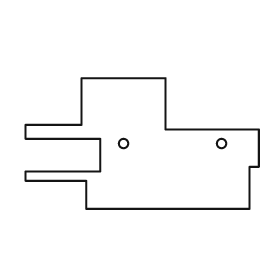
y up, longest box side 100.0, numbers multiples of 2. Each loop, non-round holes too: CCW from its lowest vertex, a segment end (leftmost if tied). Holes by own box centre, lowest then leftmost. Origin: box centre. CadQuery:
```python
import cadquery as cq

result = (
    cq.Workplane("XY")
    .moveTo(-24.0, -28.0)
    .lineTo(46.0, -28.0)
    .lineTo(46.0, -10.0)
    .lineTo(50.0, -10.0)
    .lineTo(50.0, 6.0)
    .lineTo(10.0, 6.0)
    .lineTo(10.0, 28.0)
    .lineTo(-26.0, 28.0)
    .lineTo(-26.0, 8.0)
    .lineTo(-50.0, 8.0)
    .lineTo(-50.0, 2.0)
    .lineTo(-18.0, 2.0)
    .lineTo(-18.0, -12.0)
    .lineTo(-50.0, -12.0)
    .lineTo(-50.0, -16.0)
    .lineTo(-24.0, -16.0)
    .close()
    .moveTo(-8.0, 0.0)
    .circle(2.0)
    .moveTo(34.0, 0.0)
    .circle(2.0)
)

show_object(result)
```